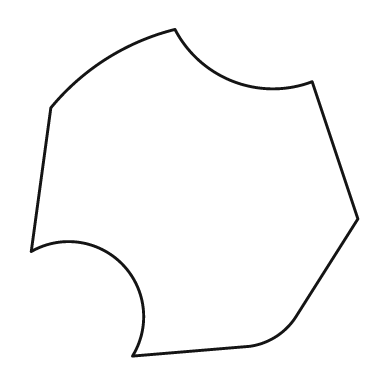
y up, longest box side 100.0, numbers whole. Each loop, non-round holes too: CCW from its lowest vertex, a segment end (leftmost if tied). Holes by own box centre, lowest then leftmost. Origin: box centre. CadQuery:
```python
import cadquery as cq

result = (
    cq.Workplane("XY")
    .moveTo(-19.0, -50.0)
    .lineTo(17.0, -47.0)
    .threePointArc((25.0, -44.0), (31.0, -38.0))
    .lineTo(50.0, -8.0)
    .lineTo(36.0, 34.0)
    .threePointArc((12.0, 34.0), (-6.0, 50.0))
    .threePointArc((-27.0, 41.0), (-44.0, 26.0))
    .lineTo(-50.0, -18.0)
    .threePointArc((-22.0, -22.0), (-19.0, -50.0))
    .close()
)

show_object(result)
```